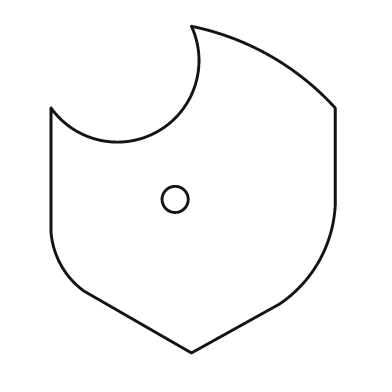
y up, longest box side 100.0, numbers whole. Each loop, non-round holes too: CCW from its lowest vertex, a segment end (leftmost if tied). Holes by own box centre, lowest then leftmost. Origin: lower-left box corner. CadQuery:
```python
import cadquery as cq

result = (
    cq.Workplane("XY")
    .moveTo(43.0, 0.0)
    .lineTo(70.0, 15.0)
    .threePointArc((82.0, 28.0), (87.0, 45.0))
    .lineTo(87.0, 75.0)
    .threePointArc((67.0, 91.0), (43.0, 100.0))
    .threePointArc((33.0, 68.0), (0.0, 75.0))
    .lineTo(0.0, 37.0)
    .threePointArc((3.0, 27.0), (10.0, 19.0))
    .close()
    .moveTo(38.0, 47.0)
    .circle(4.0)
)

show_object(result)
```